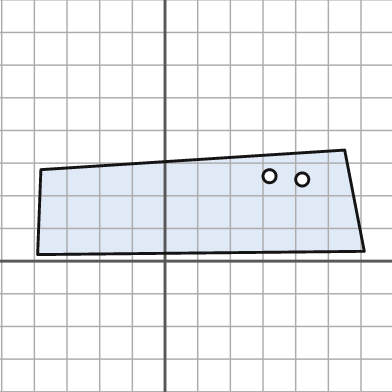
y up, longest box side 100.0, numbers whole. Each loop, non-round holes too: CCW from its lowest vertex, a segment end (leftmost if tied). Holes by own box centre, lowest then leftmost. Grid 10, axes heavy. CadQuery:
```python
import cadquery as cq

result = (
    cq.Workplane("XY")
    .moveTo(-39.0, 2.0)
    .lineTo(61.0, 3.0)
    .lineTo(55.0, 34.0)
    .lineTo(-38.0, 28.0)
    .close()
    .moveTo(42.0, 25.0)
    .circle(2.0)
    .moveTo(32.0, 26.0)
    .circle(2.0)
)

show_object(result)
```